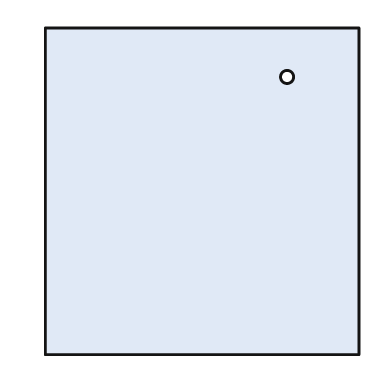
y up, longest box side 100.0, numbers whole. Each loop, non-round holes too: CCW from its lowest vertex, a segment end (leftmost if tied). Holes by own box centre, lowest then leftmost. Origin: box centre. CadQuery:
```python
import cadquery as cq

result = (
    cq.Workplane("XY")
    .moveTo(-48.0, -50.0)
    .lineTo(48.0, -50.0)
    .lineTo(48.0, 50.0)
    .lineTo(-48.0, 50.0)
    .close()
    .moveTo(26.0, 35.0)
    .circle(2.0)
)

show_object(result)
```